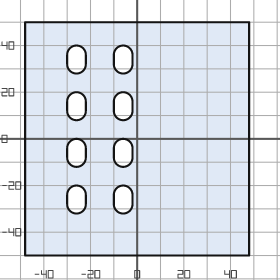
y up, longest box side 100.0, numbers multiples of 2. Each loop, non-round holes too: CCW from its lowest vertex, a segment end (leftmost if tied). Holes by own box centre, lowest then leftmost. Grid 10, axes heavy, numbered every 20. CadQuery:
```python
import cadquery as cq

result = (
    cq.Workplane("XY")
    .moveTo(-48.0, -50.0)
    .lineTo(48.0, -50.0)
    .lineTo(48.0, 50.0)
    .lineTo(-48.0, 50.0)
    .close()
    .moveTo(-30.0, -28.0)
    .threePointArc((-26.0, -32.0), (-22.0, -28.0))
    .lineTo(-22.0, -24.0)
    .threePointArc((-26.0, -20.0), (-30.0, -24.0))
    .close()
    .moveTo(-10.0, -28.0)
    .threePointArc((-6.0, -32.0), (-2.0, -28.0))
    .lineTo(-2.0, -24.0)
    .threePointArc((-6.0, -20.0), (-10.0, -24.0))
    .close()
    .moveTo(-30.0, -8.0)
    .threePointArc((-26.0, -12.0), (-22.0, -8.0))
    .lineTo(-22.0, -4.0)
    .threePointArc((-26.0, 0.0), (-30.0, -4.0))
    .close()
    .moveTo(-10.0, -8.0)
    .threePointArc((-6.0, -12.0), (-2.0, -8.0))
    .lineTo(-2.0, -4.0)
    .threePointArc((-6.0, 0.0), (-10.0, -4.0))
    .close()
    .moveTo(-30.0, 12.0)
    .threePointArc((-26.0, 8.0), (-22.0, 12.0))
    .lineTo(-22.0, 16.0)
    .threePointArc((-26.0, 20.0), (-30.0, 16.0))
    .close()
    .moveTo(-10.0, 12.0)
    .threePointArc((-6.0, 8.0), (-2.0, 12.0))
    .lineTo(-2.0, 16.0)
    .threePointArc((-6.0, 20.0), (-10.0, 16.0))
    .close()
    .moveTo(-30.0, 32.0)
    .threePointArc((-26.0, 28.0), (-22.0, 32.0))
    .lineTo(-22.0, 36.0)
    .threePointArc((-26.0, 40.0), (-30.0, 36.0))
    .close()
    .moveTo(-10.0, 32.0)
    .threePointArc((-6.0, 28.0), (-2.0, 32.0))
    .lineTo(-2.0, 36.0)
    .threePointArc((-6.0, 40.0), (-10.0, 36.0))
    .close()
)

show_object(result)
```